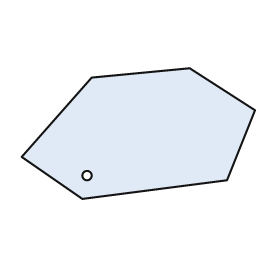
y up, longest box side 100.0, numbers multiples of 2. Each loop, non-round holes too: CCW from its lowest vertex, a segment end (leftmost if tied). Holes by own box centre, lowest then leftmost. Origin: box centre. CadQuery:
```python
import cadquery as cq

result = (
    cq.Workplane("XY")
    .moveTo(-24.0, -28.0)
    .lineTo(38.0, -20.0)
    .lineTo(50.0, 10.0)
    .lineTo(22.0, 28.0)
    .lineTo(-20.0, 24.0)
    .lineTo(-50.0, -10.0)
    .close()
    .moveTo(-22.0, -18.0)
    .circle(2.0)
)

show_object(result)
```